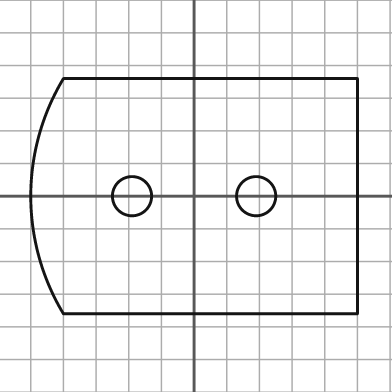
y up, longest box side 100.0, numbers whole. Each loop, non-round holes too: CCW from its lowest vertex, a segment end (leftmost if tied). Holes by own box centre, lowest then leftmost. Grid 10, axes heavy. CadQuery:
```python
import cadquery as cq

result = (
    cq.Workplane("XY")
    .moveTo(-40.0, -36.0)
    .lineTo(50.0, -36.0)
    .lineTo(50.0, 36.0)
    .lineTo(-40.0, 36.0)
    .threePointArc((-50.0, 0.0), (-40.0, -36.0))
    .close()
    .moveTo(-19.0, 0.0)
    .circle(6.0)
    .moveTo(19.0, 0.0)
    .circle(6.0)
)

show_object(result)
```